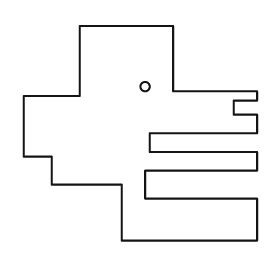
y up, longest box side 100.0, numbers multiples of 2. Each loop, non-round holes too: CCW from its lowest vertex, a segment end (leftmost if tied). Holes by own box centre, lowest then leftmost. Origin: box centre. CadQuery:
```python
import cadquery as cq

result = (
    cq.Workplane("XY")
    .moveTo(-8.0, -46.0)
    .lineTo(50.0, -46.0)
    .lineTo(50.0, -28.0)
    .lineTo(2.0, -28.0)
    .lineTo(2.0, -16.0)
    .lineTo(50.0, -16.0)
    .lineTo(50.0, -8.0)
    .lineTo(4.0, -8.0)
    .lineTo(4.0, 0.0)
    .lineTo(50.0, 0.0)
    .lineTo(50.0, 8.0)
    .lineTo(40.0, 8.0)
    .lineTo(40.0, 14.0)
    .lineTo(50.0, 14.0)
    .lineTo(50.0, 18.0)
    .lineTo(14.0, 18.0)
    .lineTo(14.0, 46.0)
    .lineTo(-26.0, 46.0)
    .lineTo(-26.0, 16.0)
    .lineTo(-50.0, 16.0)
    .lineTo(-50.0, -10.0)
    .lineTo(-38.0, -10.0)
    .lineTo(-38.0, -22.0)
    .lineTo(-8.0, -22.0)
    .close()
    .moveTo(2.0, 20.0)
    .circle(2.0)
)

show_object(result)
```